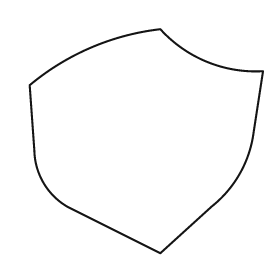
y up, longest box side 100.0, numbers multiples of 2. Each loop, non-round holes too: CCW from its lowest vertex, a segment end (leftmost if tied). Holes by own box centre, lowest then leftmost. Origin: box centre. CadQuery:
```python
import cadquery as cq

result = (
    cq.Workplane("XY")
    .moveTo(6.0, -48.0)
    .lineTo(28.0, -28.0)
    .threePointArc((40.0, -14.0), (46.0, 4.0))
    .lineTo(50.0, 30.0)
    .threePointArc((26.0, 34.0), (6.0, 48.0))
    .threePointArc((-24.0, 40.0), (-50.0, 24.0))
    .lineTo(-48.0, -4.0)
    .threePointArc((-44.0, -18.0), (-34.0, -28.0))
    .close()
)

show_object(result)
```